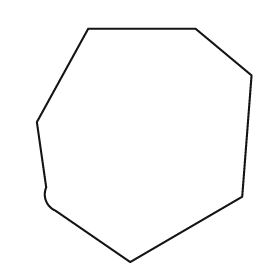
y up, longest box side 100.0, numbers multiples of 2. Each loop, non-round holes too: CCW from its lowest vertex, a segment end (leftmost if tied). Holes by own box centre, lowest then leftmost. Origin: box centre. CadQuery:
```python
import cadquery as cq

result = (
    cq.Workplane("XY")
    .moveTo(-6.0, -50.0)
    .lineTo(42.0, -22.0)
    .lineTo(46.0, 30.0)
    .lineTo(22.0, 50.0)
    .lineTo(-24.0, 50.0)
    .lineTo(-46.0, 10.0)
    .lineTo(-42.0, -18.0)
    .threePointArc((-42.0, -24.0), (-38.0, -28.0))
    .close()
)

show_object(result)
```